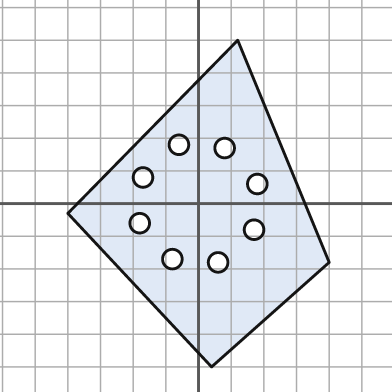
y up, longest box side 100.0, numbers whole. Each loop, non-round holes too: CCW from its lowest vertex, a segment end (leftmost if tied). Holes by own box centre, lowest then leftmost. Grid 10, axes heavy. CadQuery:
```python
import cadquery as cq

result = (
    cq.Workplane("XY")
    .moveTo(4.0, -50.0)
    .lineTo(40.0, -18.0)
    .lineTo(12.0, 50.0)
    .lineTo(-40.0, -3.0)
    .close()
    .moveTo(6.0, -18.0)
    .circle(3.0)
    .moveTo(-8.0, -17.0)
    .circle(3.0)
    .moveTo(17.0, -8.0)
    .circle(3.0)
    .moveTo(-18.0, -6.0)
    .circle(3.0)
    .moveTo(18.0, 6.0)
    .circle(3.0)
    .moveTo(-17.0, 8.0)
    .circle(3.0)
    .moveTo(8.0, 17.0)
    .circle(3.0)
    .moveTo(-6.0, 18.0)
    .circle(3.0)
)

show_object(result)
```